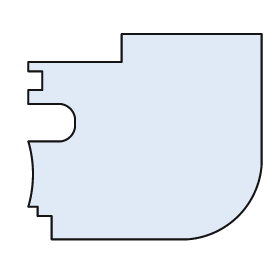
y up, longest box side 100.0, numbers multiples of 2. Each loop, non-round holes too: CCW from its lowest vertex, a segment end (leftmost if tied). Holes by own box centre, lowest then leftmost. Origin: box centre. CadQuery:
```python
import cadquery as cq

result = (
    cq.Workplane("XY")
    .moveTo(-40.0, -44.0)
    .lineTo(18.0, -44.0)
    .threePointArc((40.0, -34.0), (50.0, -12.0))
    .lineTo(50.0, 44.0)
    .lineTo(-10.0, 44.0)
    .lineTo(-10.0, 32.0)
    .lineTo(-50.0, 32.0)
    .lineTo(-50.0, 28.0)
    .lineTo(-44.0, 28.0)
    .lineTo(-44.0, 20.0)
    .lineTo(-50.0, 20.0)
    .lineTo(-50.0, 14.0)
    .lineTo(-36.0, 14.0)
    .threePointArc((-32.0, 12.0), (-30.0, 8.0))
    .lineTo(-30.0, 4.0)
    .threePointArc((-32.0, 0.0), (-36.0, -2.0))
    .lineTo(-50.0, -2.0)
    .threePointArc((-48.0, -16.0), (-50.0, -30.0))
    .lineTo(-46.0, -30.0)
    .lineTo(-46.0, -34.0)
    .lineTo(-40.0, -34.0)
    .close()
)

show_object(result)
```